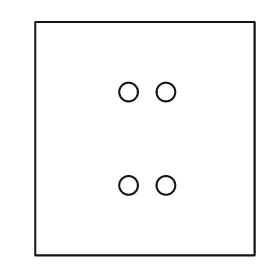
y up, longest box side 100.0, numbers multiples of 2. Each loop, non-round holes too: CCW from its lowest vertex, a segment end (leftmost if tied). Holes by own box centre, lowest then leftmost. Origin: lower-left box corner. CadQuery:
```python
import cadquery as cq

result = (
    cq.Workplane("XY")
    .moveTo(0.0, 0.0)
    .lineTo(94.0, 0.0)
    .lineTo(94.0, 100.0)
    .lineTo(0.0, 100.0)
    .close()
    .moveTo(40.0, 30.0)
    .circle(4.0)
    .moveTo(56.0, 30.0)
    .circle(4.0)
    .moveTo(40.0, 70.0)
    .circle(4.0)
    .moveTo(56.0, 70.0)
    .circle(4.0)
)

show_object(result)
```